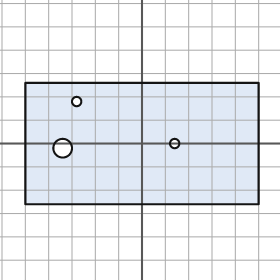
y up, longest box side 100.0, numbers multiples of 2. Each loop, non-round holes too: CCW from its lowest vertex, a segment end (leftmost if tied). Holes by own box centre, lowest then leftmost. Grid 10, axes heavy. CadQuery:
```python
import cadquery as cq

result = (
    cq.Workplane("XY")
    .moveTo(-50.0, -26.0)
    .lineTo(50.0, -26.0)
    .lineTo(50.0, 26.0)
    .lineTo(-50.0, 26.0)
    .close()
    .moveTo(-34.0, -2.0)
    .circle(4.0)
    .moveTo(14.0, 0.0)
    .circle(2.0)
    .moveTo(-28.0, 18.0)
    .circle(2.0)
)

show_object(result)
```